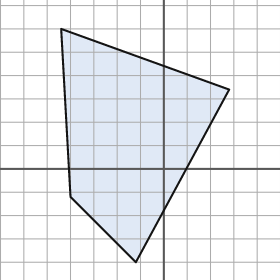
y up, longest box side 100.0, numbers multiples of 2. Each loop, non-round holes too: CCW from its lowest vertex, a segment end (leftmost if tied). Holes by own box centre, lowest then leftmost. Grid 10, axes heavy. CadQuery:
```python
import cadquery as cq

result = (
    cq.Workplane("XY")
    .moveTo(-12.0, -40.0)
    .lineTo(28.0, 34.0)
    .lineTo(-44.0, 60.0)
    .lineTo(-40.0, -12.0)
    .close()
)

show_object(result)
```